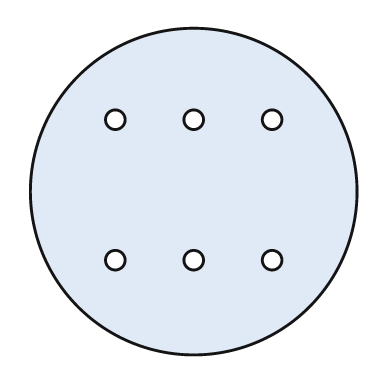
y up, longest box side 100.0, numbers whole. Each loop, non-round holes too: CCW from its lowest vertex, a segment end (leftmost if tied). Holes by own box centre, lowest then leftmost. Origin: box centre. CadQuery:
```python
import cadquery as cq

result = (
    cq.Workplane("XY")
    .moveTo(0.0, 0.0)
    .circle(50.0)
    .moveTo(-24.0, -21.0)
    .circle(3.0)
    .moveTo(0.0, -21.0)
    .circle(3.0)
    .moveTo(24.0, -21.0)
    .circle(3.0)
    .moveTo(-24.0, 22.0)
    .circle(3.0)
    .moveTo(0.0, 22.0)
    .circle(3.0)
    .moveTo(24.0, 22.0)
    .circle(3.0)
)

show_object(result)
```